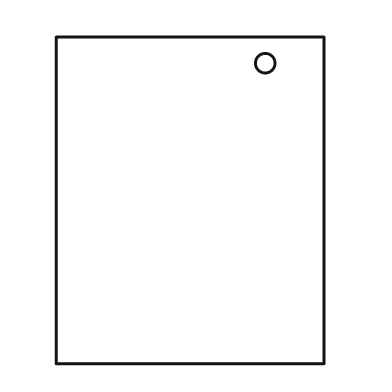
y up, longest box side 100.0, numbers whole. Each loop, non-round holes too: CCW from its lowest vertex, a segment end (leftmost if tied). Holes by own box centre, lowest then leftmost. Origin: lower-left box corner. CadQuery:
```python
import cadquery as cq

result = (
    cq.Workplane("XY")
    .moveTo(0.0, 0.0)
    .lineTo(82.0, 0.0)
    .lineTo(82.0, 100.0)
    .lineTo(0.0, 100.0)
    .close()
    .moveTo(64.0, 92.0)
    .circle(3.0)
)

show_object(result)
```